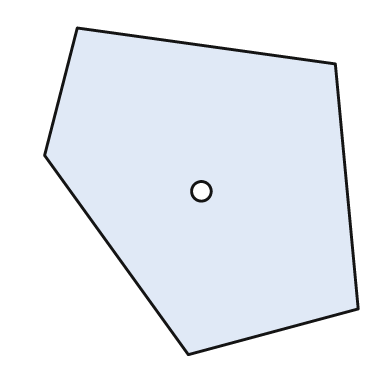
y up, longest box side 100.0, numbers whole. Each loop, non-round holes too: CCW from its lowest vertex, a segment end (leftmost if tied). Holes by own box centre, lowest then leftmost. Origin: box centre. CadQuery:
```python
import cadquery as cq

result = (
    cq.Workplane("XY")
    .moveTo(-4.0, -50.0)
    .lineTo(48.0, -36.0)
    .lineTo(41.0, 39.0)
    .lineTo(-38.0, 50.0)
    .lineTo(-48.0, 11.0)
    .close()
    .moveTo(0.0, 0.0)
    .circle(3.0)
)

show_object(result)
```